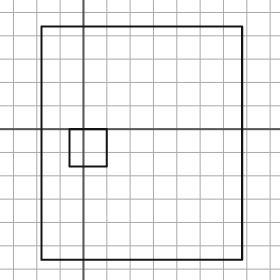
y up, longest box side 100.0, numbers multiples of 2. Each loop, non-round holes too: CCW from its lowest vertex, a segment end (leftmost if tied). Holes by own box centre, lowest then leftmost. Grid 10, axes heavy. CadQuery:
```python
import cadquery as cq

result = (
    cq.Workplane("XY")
    .moveTo(-18.0, -56.0)
    .lineTo(68.0, -56.0)
    .lineTo(68.0, 44.0)
    .lineTo(-18.0, 44.0)
    .close()
    .moveTo(-6.0, -16.0)
    .lineTo(10.0, -16.0)
    .lineTo(10.0, 0.0)
    .lineTo(-6.0, 0.0)
    .close()
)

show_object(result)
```